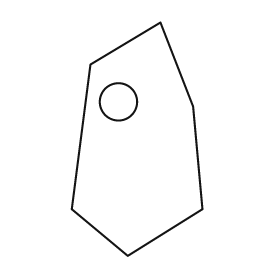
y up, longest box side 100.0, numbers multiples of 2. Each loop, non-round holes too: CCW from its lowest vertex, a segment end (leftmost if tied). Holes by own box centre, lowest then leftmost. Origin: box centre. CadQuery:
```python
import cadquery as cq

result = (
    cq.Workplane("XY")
    .moveTo(-4.0, -50.0)
    .lineTo(28.0, -30.0)
    .lineTo(24.0, 14.0)
    .lineTo(10.0, 50.0)
    .lineTo(-20.0, 32.0)
    .lineTo(-28.0, -30.0)
    .close()
    .moveTo(-8.0, 16.0)
    .circle(8.0)
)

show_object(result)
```